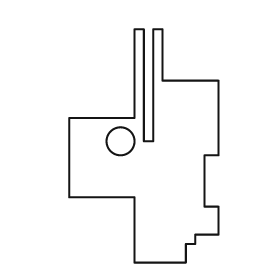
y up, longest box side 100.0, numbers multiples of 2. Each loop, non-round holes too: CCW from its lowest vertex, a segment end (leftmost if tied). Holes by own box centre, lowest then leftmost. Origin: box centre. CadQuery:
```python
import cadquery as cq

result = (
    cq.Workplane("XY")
    .moveTo(-4.0, -50.0)
    .lineTo(18.0, -50.0)
    .lineTo(18.0, -42.0)
    .lineTo(22.0, -42.0)
    .lineTo(22.0, -38.0)
    .lineTo(32.0, -38.0)
    .lineTo(32.0, -26.0)
    .lineTo(26.0, -26.0)
    .lineTo(26.0, -4.0)
    .lineTo(32.0, -4.0)
    .lineTo(32.0, 28.0)
    .lineTo(8.0, 28.0)
    .lineTo(8.0, 50.0)
    .lineTo(4.0, 50.0)
    .lineTo(4.0, 2.0)
    .lineTo(0.0, 2.0)
    .lineTo(0.0, 50.0)
    .lineTo(-4.0, 50.0)
    .lineTo(-4.0, 12.0)
    .lineTo(-32.0, 12.0)
    .lineTo(-32.0, -22.0)
    .lineTo(-4.0, -22.0)
    .close()
    .moveTo(-10.0, 2.0)
    .circle(6.0)
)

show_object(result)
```